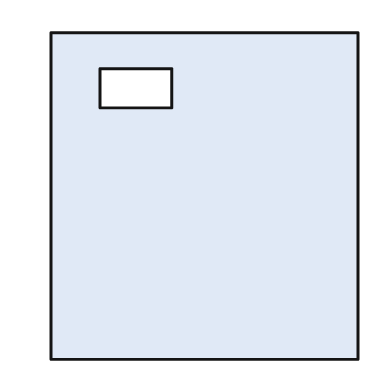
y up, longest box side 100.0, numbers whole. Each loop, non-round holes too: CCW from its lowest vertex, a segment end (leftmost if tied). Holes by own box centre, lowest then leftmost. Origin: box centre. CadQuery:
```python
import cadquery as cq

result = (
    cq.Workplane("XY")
    .moveTo(-47.0, -50.0)
    .lineTo(47.0, -50.0)
    .lineTo(47.0, 50.0)
    .lineTo(-47.0, 50.0)
    .close()
    .moveTo(-32.0, 27.0)
    .lineTo(-10.0, 27.0)
    .lineTo(-10.0, 39.0)
    .lineTo(-32.0, 39.0)
    .close()
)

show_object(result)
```